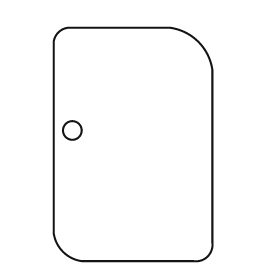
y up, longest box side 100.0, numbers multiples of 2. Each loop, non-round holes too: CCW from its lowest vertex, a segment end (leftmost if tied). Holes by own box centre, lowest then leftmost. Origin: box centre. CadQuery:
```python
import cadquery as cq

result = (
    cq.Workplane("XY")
    .moveTo(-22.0, -50.0)
    .lineTo(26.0, -50.0)
    .threePointArc((32.0, -48.0), (34.0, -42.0))
    .lineTo(34.0, 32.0)
    .threePointArc((28.0, 44.0), (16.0, 50.0))
    .lineTo(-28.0, 50.0)
    .threePointArc((-32.0, 48.0), (-34.0, 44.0))
    .lineTo(-34.0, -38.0)
    .threePointArc((-30.0, -46.0), (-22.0, -50.0))
    .close()
    .moveTo(-26.0, 6.0)
    .circle(4.0)
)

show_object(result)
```